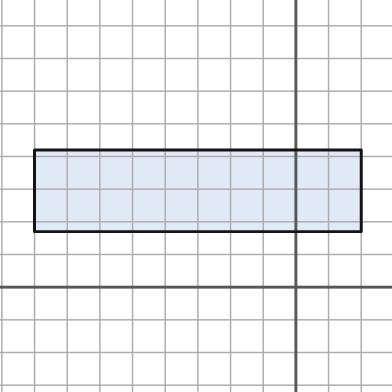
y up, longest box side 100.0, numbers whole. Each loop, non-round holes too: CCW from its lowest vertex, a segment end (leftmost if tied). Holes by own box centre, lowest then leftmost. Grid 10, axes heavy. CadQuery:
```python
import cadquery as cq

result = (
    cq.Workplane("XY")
    .moveTo(-80.0, 17.0)
    .lineTo(20.0, 17.0)
    .lineTo(20.0, 42.0)
    .lineTo(-80.0, 42.0)
    .close()
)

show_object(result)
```